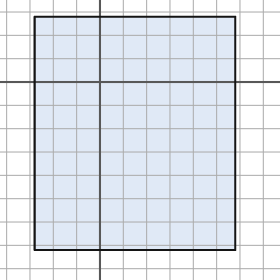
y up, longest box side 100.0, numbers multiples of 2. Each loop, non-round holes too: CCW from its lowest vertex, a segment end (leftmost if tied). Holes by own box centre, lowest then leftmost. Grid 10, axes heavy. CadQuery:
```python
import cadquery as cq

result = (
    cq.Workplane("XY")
    .moveTo(-28.0, -72.0)
    .lineTo(58.0, -72.0)
    .lineTo(58.0, 28.0)
    .lineTo(-28.0, 28.0)
    .close()
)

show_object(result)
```